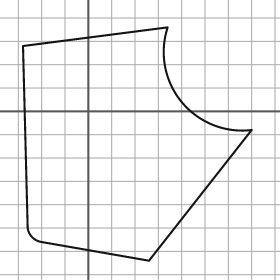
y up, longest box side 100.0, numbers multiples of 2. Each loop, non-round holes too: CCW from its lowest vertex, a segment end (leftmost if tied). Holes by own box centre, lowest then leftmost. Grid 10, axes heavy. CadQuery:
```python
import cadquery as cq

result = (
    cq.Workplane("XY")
    .moveTo(26.0, -64.0)
    .lineTo(70.0, -8.0)
    .threePointArc((40.0, 4.0), (34.0, 36.0))
    .lineTo(-28.0, 28.0)
    .lineTo(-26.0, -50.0)
    .threePointArc((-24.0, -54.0), (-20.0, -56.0))
    .close()
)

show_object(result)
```